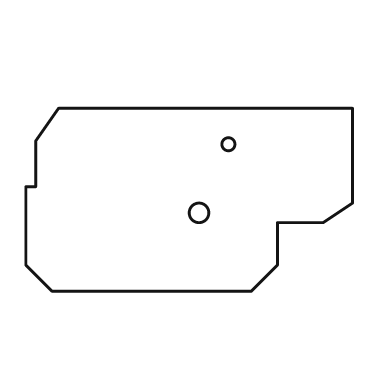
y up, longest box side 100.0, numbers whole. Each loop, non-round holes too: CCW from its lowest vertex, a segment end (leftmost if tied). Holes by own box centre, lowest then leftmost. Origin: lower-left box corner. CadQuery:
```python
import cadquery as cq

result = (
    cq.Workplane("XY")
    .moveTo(8.0, 0.0)
    .lineTo(69.0, 0.0)
    .lineTo(77.0, 8.0)
    .lineTo(77.0, 21.0)
    .lineTo(91.0, 21.0)
    .lineTo(100.0, 27.0)
    .lineTo(100.0, 56.0)
    .lineTo(10.0, 56.0)
    .lineTo(3.0, 46.0)
    .lineTo(3.0, 32.0)
    .lineTo(0.0, 32.0)
    .lineTo(0.0, 8.0)
    .close()
    .moveTo(53.0, 24.0)
    .circle(3.0)
    .moveTo(62.0, 45.0)
    .circle(2.0)
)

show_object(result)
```